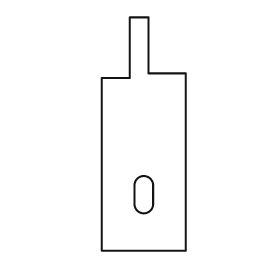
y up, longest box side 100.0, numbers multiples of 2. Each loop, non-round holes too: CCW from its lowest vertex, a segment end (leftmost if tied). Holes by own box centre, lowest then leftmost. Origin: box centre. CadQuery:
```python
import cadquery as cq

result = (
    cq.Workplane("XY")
    .moveTo(-18.0, -50.0)
    .lineTo(18.0, -50.0)
    .lineTo(18.0, 26.0)
    .lineTo(2.0, 26.0)
    .lineTo(2.0, 50.0)
    .lineTo(-6.0, 50.0)
    .lineTo(-6.0, 24.0)
    .lineTo(-18.0, 24.0)
    .close()
    .moveTo(-4.0, -30.0)
    .threePointArc((0.0, -34.0), (4.0, -30.0))
    .lineTo(4.0, -22.0)
    .threePointArc((0.0, -18.0), (-4.0, -22.0))
    .close()
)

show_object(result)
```